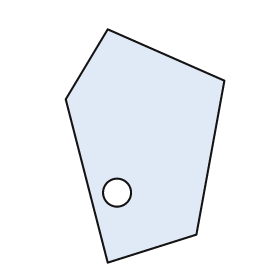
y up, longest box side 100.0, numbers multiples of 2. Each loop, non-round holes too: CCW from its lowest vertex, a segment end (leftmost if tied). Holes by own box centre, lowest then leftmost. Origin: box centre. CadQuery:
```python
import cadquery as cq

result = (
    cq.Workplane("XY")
    .moveTo(-16.0, -50.0)
    .lineTo(22.0, -38.0)
    .lineTo(34.0, 28.0)
    .lineTo(-16.0, 50.0)
    .lineTo(-34.0, 20.0)
    .close()
    .moveTo(-12.0, -20.0)
    .circle(6.0)
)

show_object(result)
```